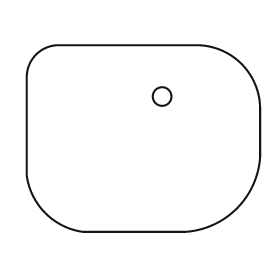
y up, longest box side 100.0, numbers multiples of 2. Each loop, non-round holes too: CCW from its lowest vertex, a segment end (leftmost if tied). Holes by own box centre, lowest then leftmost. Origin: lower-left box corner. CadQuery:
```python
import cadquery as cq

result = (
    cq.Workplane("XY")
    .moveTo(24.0, 0.0)
    .lineTo(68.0, 0.0)
    .threePointArc((90.0, 10.0), (100.0, 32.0))
    .lineTo(100.0, 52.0)
    .threePointArc((92.0, 72.0), (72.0, 80.0))
    .lineTo(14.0, 80.0)
    .threePointArc((4.0, 76.0), (0.0, 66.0))
    .lineTo(0.0, 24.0)
    .threePointArc((8.0, 8.0), (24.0, 0.0))
    .close()
    .moveTo(58.0, 58.0)
    .circle(4.0)
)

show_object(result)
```